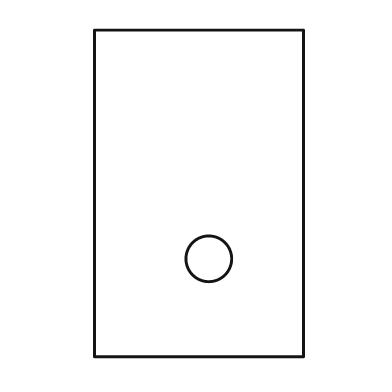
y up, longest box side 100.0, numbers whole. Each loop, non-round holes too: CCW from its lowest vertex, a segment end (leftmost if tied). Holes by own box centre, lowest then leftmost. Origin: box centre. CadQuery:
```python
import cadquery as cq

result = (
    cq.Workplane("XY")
    .moveTo(-32.0, -50.0)
    .lineTo(32.0, -50.0)
    .lineTo(32.0, 50.0)
    .lineTo(-32.0, 50.0)
    .close()
    .moveTo(3.0, -20.0)
    .circle(7.0)
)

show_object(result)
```